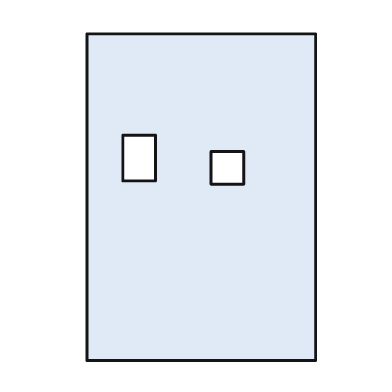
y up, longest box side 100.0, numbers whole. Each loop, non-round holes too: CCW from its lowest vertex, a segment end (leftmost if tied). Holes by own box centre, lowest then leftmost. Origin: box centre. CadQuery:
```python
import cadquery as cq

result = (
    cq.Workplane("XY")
    .moveTo(-35.0, -50.0)
    .lineTo(35.0, -50.0)
    .lineTo(35.0, 50.0)
    .lineTo(-35.0, 50.0)
    .close()
    .moveTo(3.0, 4.0)
    .lineTo(13.0, 4.0)
    .lineTo(13.0, 14.0)
    .lineTo(3.0, 14.0)
    .close()
    .moveTo(-24.0, 5.0)
    .lineTo(-14.0, 5.0)
    .lineTo(-14.0, 19.0)
    .lineTo(-24.0, 19.0)
    .close()
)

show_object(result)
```